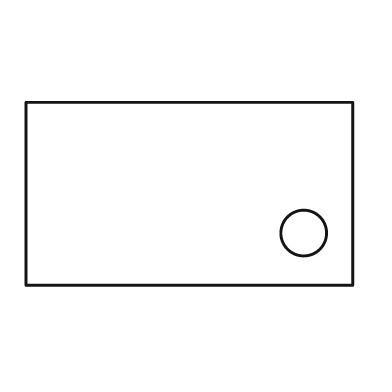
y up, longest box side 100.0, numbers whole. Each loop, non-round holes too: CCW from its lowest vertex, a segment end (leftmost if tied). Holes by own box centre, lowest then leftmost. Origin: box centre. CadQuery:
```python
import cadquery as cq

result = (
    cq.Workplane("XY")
    .moveTo(-50.0, -28.0)
    .lineTo(50.0, -28.0)
    .lineTo(50.0, 28.0)
    .lineTo(-50.0, 28.0)
    .close()
    .moveTo(35.0, -12.0)
    .circle(7.0)
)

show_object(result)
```